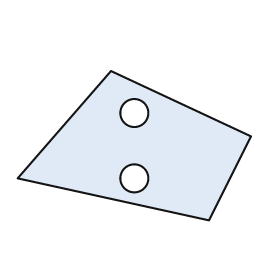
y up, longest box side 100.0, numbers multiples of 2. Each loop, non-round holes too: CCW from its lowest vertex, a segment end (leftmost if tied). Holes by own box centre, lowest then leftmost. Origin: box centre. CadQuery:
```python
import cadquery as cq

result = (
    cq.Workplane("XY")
    .moveTo(32.0, -32.0)
    .lineTo(50.0, 4.0)
    .lineTo(-10.0, 32.0)
    .lineTo(-50.0, -14.0)
    .close()
    .moveTo(0.0, -14.0)
    .circle(6.0)
    .moveTo(0.0, 14.0)
    .circle(6.0)
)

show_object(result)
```